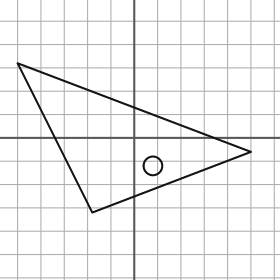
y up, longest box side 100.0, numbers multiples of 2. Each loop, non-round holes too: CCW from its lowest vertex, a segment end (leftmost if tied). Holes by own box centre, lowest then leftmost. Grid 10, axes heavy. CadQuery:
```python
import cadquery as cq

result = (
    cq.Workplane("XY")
    .moveTo(-18.0, -32.0)
    .lineTo(50.0, -6.0)
    .lineTo(-50.0, 32.0)
    .close()
    .moveTo(8.0, -12.0)
    .circle(4.0)
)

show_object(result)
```